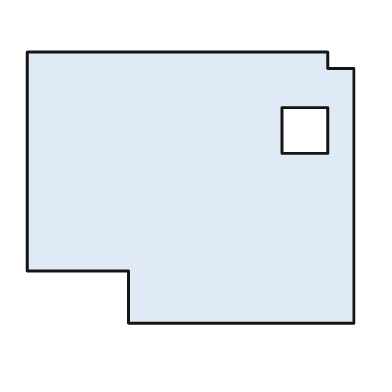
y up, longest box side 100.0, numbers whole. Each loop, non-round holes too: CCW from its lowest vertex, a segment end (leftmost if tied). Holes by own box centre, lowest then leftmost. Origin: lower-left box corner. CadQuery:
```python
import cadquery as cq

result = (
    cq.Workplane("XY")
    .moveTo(31.0, 0.0)
    .lineTo(100.0, 0.0)
    .lineTo(100.0, 78.0)
    .lineTo(92.0, 78.0)
    .lineTo(92.0, 83.0)
    .lineTo(0.0, 83.0)
    .lineTo(0.0, 16.0)
    .lineTo(31.0, 16.0)
    .close()
    .moveTo(78.0, 52.0)
    .lineTo(92.0, 52.0)
    .lineTo(92.0, 66.0)
    .lineTo(78.0, 66.0)
    .close()
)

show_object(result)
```